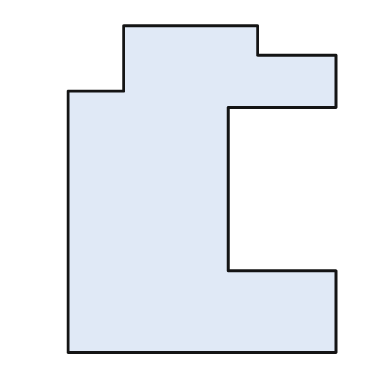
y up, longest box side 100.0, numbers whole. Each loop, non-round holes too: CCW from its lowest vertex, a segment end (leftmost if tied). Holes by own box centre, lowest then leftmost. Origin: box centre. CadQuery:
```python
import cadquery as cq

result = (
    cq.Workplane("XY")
    .moveTo(-41.0, -50.0)
    .lineTo(41.0, -50.0)
    .lineTo(41.0, -25.0)
    .lineTo(8.0, -25.0)
    .lineTo(8.0, 25.0)
    .lineTo(41.0, 25.0)
    .lineTo(41.0, 41.0)
    .lineTo(17.0, 41.0)
    .lineTo(17.0, 50.0)
    .lineTo(-24.0, 50.0)
    .lineTo(-24.0, 30.0)
    .lineTo(-41.0, 30.0)
    .close()
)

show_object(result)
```